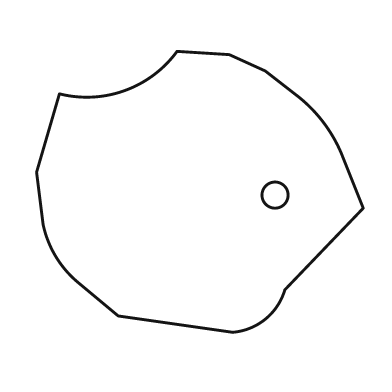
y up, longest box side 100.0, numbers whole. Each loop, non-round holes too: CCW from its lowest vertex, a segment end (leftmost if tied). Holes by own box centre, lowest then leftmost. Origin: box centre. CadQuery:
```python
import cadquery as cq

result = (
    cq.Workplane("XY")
    .moveTo(10.0, -43.0)
    .threePointArc((20.0, -39.0), (26.0, -30.0))
    .lineTo(50.0, -5.0)
    .lineTo(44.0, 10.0)
    .threePointArc((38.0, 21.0), (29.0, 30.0))
    .lineTo(20.0, 37.0)
    .lineTo(9.0, 42.0)
    .lineTo(-7.0, 43.0)
    .threePointArc((-23.0, 31.0), (-43.0, 30.0))
    .lineTo(-50.0, 6.0)
    .lineTo(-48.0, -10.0)
    .threePointArc((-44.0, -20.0), (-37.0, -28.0))
    .lineTo(-25.0, -38.0)
    .close()
    .moveTo(23.0, -1.0)
    .circle(4.0)
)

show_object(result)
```